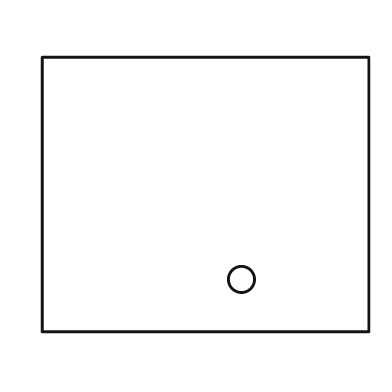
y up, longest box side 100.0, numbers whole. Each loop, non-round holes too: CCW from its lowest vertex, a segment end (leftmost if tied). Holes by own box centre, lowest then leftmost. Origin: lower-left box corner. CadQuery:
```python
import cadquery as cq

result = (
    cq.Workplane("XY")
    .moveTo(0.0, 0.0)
    .lineTo(100.0, 0.0)
    .lineTo(100.0, 84.0)
    .lineTo(0.0, 84.0)
    .close()
    .moveTo(61.0, 16.0)
    .circle(4.0)
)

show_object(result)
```